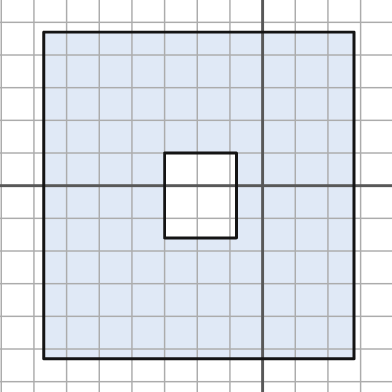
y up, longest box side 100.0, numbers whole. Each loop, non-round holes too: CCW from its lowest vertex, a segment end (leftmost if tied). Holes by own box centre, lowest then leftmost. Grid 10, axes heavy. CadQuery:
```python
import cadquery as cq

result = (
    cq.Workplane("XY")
    .moveTo(-67.0, -53.0)
    .lineTo(28.0, -53.0)
    .lineTo(28.0, 47.0)
    .lineTo(-67.0, 47.0)
    .close()
    .moveTo(-30.0, -16.0)
    .lineTo(-8.0, -16.0)
    .lineTo(-8.0, 10.0)
    .lineTo(-30.0, 10.0)
    .close()
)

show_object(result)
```